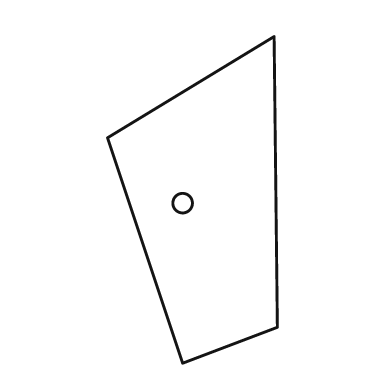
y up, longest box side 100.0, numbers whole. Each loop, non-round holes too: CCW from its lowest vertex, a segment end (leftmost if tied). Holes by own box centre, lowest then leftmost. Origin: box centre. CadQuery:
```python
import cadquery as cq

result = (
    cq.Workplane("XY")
    .moveTo(-3.0, -50.0)
    .lineTo(26.0, -39.0)
    .lineTo(25.0, 50.0)
    .lineTo(-26.0, 19.0)
    .close()
    .moveTo(-3.0, -1.0)
    .circle(3.0)
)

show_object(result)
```